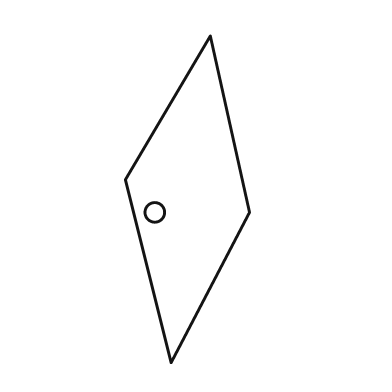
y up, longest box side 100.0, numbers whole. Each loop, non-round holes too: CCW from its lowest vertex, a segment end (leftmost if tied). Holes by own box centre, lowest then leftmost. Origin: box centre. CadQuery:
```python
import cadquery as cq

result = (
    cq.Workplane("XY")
    .moveTo(-5.0, -50.0)
    .lineTo(19.0, -4.0)
    .lineTo(7.0, 50.0)
    .lineTo(-19.0, 6.0)
    .close()
    .moveTo(-10.0, -4.0)
    .circle(3.0)
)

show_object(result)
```